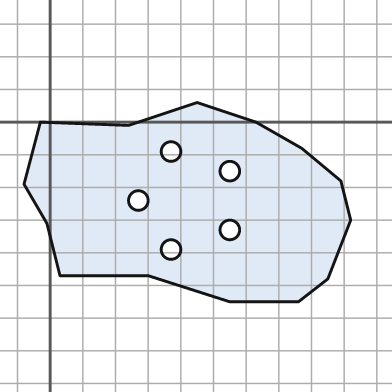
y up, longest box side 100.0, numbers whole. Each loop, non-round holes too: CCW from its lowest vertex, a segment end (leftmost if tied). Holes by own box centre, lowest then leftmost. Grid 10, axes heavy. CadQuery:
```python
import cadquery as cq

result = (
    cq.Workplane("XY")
    .moveTo(55.0, -55.0)
    .lineTo(76.0, -55.0)
    .lineTo(85.0, -48.0)
    .lineTo(92.0, -30.0)
    .lineTo(89.0, -18.0)
    .lineTo(77.0, -8.0)
    .lineTo(63.0, 0.0)
    .lineTo(45.0, 6.0)
    .lineTo(24.0, -1.0)
    .lineTo(-3.0, 0.0)
    .lineTo(-8.0, -19.0)
    .lineTo(-1.0, -31.0)
    .lineTo(3.0, -47.0)
    .lineTo(30.0, -47.0)
    .close()
    .moveTo(37.0, -39.0)
    .circle(3.0)
    .moveTo(55.0, -33.0)
    .circle(3.0)
    .moveTo(27.0, -24.0)
    .circle(3.0)
    .moveTo(55.0, -15.0)
    .circle(3.0)
    .moveTo(37.0, -9.0)
    .circle(3.0)
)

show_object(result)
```